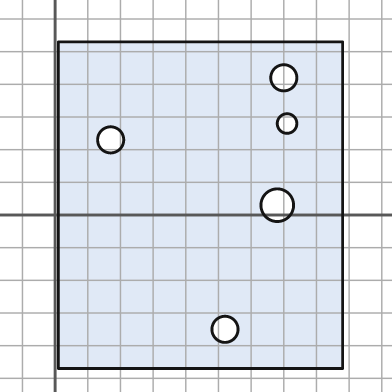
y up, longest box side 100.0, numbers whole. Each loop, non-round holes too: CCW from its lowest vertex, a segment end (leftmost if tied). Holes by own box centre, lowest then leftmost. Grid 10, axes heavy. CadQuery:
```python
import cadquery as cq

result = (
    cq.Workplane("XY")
    .moveTo(1.0, -47.0)
    .lineTo(88.0, -47.0)
    .lineTo(88.0, 53.0)
    .lineTo(1.0, 53.0)
    .close()
    .moveTo(52.0, -35.0)
    .circle(4.0)
    .moveTo(68.0, 3.0)
    .circle(5.0)
    .moveTo(17.0, 23.0)
    .circle(4.0)
    .moveTo(71.0, 28.0)
    .circle(3.0)
    .moveTo(70.0, 42.0)
    .circle(4.0)
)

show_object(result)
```